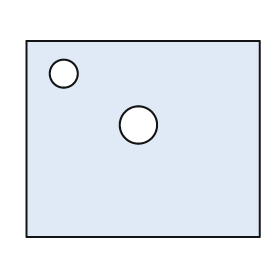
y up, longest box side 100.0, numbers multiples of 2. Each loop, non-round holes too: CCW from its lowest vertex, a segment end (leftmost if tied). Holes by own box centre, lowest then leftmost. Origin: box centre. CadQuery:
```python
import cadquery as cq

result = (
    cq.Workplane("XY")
    .moveTo(-50.0, -42.0)
    .lineTo(50.0, -42.0)
    .lineTo(50.0, 42.0)
    .lineTo(-50.0, 42.0)
    .close()
    .moveTo(-2.0, 6.0)
    .circle(8.0)
    .moveTo(-34.0, 28.0)
    .circle(6.0)
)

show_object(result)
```